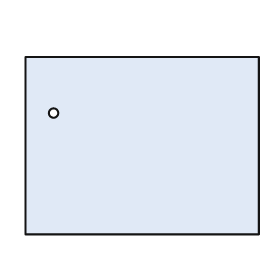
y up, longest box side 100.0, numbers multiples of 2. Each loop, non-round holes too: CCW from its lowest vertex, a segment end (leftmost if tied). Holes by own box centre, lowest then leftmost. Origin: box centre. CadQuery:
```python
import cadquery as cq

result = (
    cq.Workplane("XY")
    .moveTo(-50.0, -38.0)
    .lineTo(50.0, -38.0)
    .lineTo(50.0, 38.0)
    .lineTo(-50.0, 38.0)
    .close()
    .moveTo(-38.0, 14.0)
    .circle(2.0)
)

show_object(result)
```